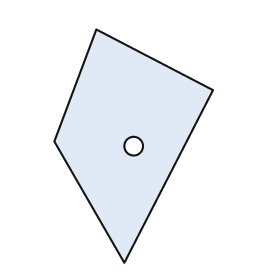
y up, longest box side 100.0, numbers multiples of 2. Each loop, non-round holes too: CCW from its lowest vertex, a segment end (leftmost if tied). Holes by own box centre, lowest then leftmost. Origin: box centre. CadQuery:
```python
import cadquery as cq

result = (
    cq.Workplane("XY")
    .moveTo(-4.0, -50.0)
    .lineTo(34.0, 24.0)
    .lineTo(-16.0, 50.0)
    .lineTo(-34.0, 2.0)
    .close()
    .moveTo(0.0, 0.0)
    .circle(4.0)
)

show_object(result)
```